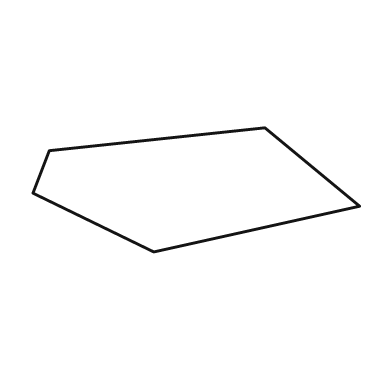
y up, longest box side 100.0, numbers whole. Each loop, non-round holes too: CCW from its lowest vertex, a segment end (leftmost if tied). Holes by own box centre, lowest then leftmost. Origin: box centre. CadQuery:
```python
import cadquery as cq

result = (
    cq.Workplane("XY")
    .moveTo(-13.0, -19.0)
    .lineTo(50.0, -5.0)
    .lineTo(21.0, 19.0)
    .lineTo(-45.0, 12.0)
    .lineTo(-50.0, -1.0)
    .close()
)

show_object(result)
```